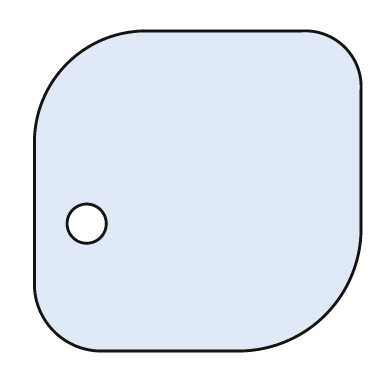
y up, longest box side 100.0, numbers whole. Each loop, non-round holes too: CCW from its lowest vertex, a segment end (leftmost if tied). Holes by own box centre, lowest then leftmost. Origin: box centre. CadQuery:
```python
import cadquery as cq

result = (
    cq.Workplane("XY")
    .moveTo(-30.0, -49.0)
    .lineTo(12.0, -49.0)
    .threePointArc((39.0, -38.0), (50.0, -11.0))
    .lineTo(50.0, 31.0)
    .threePointArc((45.0, 44.0), (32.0, 49.0))
    .lineTo(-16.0, 49.0)
    .threePointArc((-40.0, 39.0), (-50.0, 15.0))
    .lineTo(-50.0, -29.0)
    .threePointArc((-44.0, -43.0), (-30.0, -49.0))
    .close()
    .moveTo(-34.0, -10.0)
    .circle(6.0)
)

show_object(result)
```